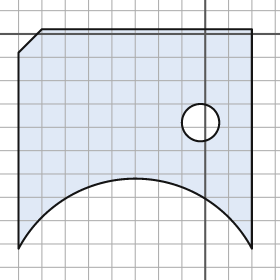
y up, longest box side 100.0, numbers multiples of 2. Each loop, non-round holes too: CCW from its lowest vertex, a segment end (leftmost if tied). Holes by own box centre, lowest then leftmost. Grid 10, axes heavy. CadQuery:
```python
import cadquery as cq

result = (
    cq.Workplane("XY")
    .moveTo(-80.0, -92.0)
    .threePointArc((-30.0, -62.0), (20.0, -92.0))
    .lineTo(20.0, 2.0)
    .lineTo(-70.0, 2.0)
    .lineTo(-80.0, -8.0)
    .close()
    .moveTo(-2.0, -38.0)
    .circle(8.0)
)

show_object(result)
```